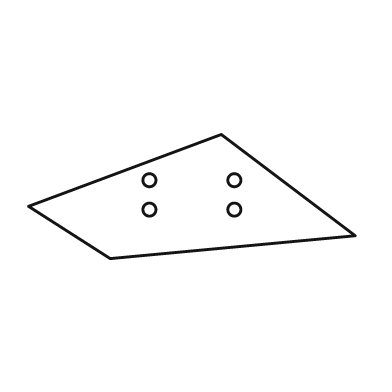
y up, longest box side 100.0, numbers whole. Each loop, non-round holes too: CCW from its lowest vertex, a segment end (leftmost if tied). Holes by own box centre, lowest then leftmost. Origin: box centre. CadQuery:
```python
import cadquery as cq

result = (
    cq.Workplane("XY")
    .moveTo(-25.0, -19.0)
    .lineTo(50.0, -12.0)
    .lineTo(9.0, 19.0)
    .lineTo(-50.0, -3.0)
    .close()
    .moveTo(-13.0, -4.0)
    .circle(2.0)
    .moveTo(13.0, -4.0)
    .circle(2.0)
    .moveTo(-13.0, 5.0)
    .circle(2.0)
    .moveTo(13.0, 5.0)
    .circle(2.0)
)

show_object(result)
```